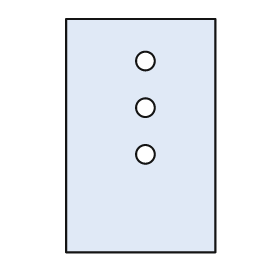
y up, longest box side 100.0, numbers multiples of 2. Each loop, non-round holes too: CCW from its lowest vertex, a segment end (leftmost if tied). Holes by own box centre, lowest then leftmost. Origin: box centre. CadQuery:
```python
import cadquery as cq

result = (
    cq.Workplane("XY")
    .moveTo(-32.0, -50.0)
    .lineTo(32.0, -50.0)
    .lineTo(32.0, 50.0)
    .lineTo(-32.0, 50.0)
    .close()
    .moveTo(2.0, -8.0)
    .circle(4.0)
    .moveTo(2.0, 12.0)
    .circle(4.0)
    .moveTo(2.0, 32.0)
    .circle(4.0)
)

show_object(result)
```